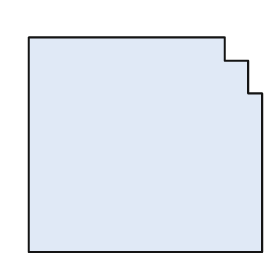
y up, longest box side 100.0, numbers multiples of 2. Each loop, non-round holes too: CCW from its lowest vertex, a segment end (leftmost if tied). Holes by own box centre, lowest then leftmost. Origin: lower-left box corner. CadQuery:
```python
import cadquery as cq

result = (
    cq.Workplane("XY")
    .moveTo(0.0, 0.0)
    .lineTo(100.0, 0.0)
    .lineTo(100.0, 68.0)
    .lineTo(94.0, 68.0)
    .lineTo(94.0, 82.0)
    .lineTo(84.0, 82.0)
    .lineTo(84.0, 92.0)
    .lineTo(0.0, 92.0)
    .close()
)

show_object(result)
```